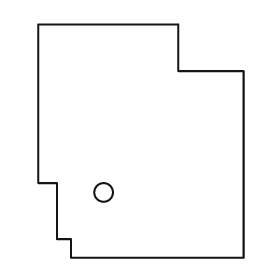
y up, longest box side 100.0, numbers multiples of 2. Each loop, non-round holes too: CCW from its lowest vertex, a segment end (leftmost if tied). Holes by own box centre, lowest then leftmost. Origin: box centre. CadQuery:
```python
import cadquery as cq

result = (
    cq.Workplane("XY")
    .moveTo(-30.0, -50.0)
    .lineTo(44.0, -50.0)
    .lineTo(44.0, 30.0)
    .lineTo(16.0, 30.0)
    .lineTo(16.0, 50.0)
    .lineTo(-44.0, 50.0)
    .lineTo(-44.0, -18.0)
    .lineTo(-36.0, -18.0)
    .lineTo(-36.0, -42.0)
    .lineTo(-30.0, -42.0)
    .close()
    .moveTo(-16.0, -22.0)
    .circle(4.0)
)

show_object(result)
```